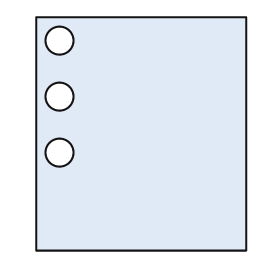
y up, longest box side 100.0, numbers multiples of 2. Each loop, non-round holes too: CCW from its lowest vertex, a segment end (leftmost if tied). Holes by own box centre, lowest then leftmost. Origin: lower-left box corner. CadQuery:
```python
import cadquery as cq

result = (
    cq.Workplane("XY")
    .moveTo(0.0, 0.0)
    .lineTo(90.0, 0.0)
    .lineTo(90.0, 100.0)
    .lineTo(0.0, 100.0)
    .close()
    .moveTo(10.0, 42.0)
    .circle(6.0)
    .moveTo(10.0, 66.0)
    .circle(6.0)
    .moveTo(10.0, 90.0)
    .circle(6.0)
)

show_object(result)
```